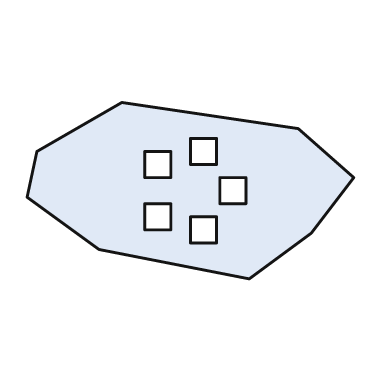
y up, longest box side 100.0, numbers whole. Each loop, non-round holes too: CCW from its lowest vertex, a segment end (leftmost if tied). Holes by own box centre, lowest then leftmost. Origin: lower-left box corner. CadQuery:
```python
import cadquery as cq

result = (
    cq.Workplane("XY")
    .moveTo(68.0, 0.0)
    .lineTo(87.0, 14.0)
    .lineTo(100.0, 31.0)
    .lineTo(83.0, 46.0)
    .lineTo(29.0, 54.0)
    .lineTo(3.0, 39.0)
    .lineTo(0.0, 25.0)
    .lineTo(22.0, 9.0)
    .close()
    .moveTo(50.0, 11.0)
    .lineTo(58.0, 11.0)
    .lineTo(58.0, 19.0)
    .lineTo(50.0, 19.0)
    .close()
    .moveTo(36.0, 15.0)
    .lineTo(44.0, 15.0)
    .lineTo(44.0, 23.0)
    .lineTo(36.0, 23.0)
    .close()
    .moveTo(59.0, 23.0)
    .lineTo(67.0, 23.0)
    .lineTo(67.0, 31.0)
    .lineTo(59.0, 31.0)
    .close()
    .moveTo(36.0, 31.0)
    .lineTo(44.0, 31.0)
    .lineTo(44.0, 39.0)
    .lineTo(36.0, 39.0)
    .close()
    .moveTo(50.0, 35.0)
    .lineTo(58.0, 35.0)
    .lineTo(58.0, 43.0)
    .lineTo(50.0, 43.0)
    .close()
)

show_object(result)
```